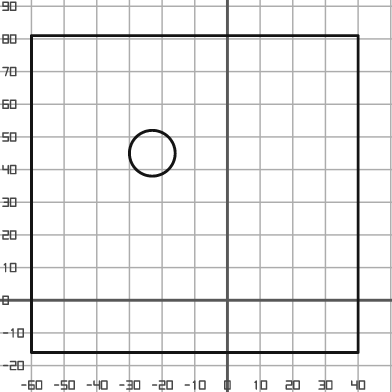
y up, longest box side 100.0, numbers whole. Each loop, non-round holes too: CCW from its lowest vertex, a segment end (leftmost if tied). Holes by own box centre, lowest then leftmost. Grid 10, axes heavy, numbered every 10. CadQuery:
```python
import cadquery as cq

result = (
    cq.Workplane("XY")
    .moveTo(-60.0, -16.0)
    .lineTo(40.0, -16.0)
    .lineTo(40.0, 81.0)
    .lineTo(-60.0, 81.0)
    .close()
    .moveTo(-23.0, 45.0)
    .circle(7.0)
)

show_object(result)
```